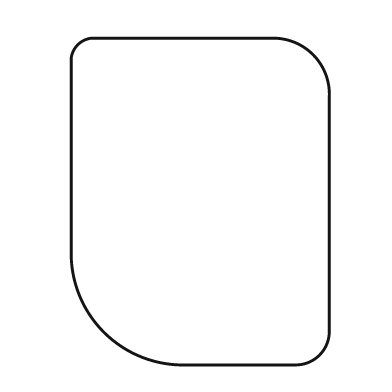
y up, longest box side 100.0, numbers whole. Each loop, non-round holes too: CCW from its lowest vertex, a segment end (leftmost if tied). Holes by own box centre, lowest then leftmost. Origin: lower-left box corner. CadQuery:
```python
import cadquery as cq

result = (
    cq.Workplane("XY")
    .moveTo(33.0, 0.0)
    .lineTo(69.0, 0.0)
    .threePointArc((76.0, 3.0), (79.0, 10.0))
    .lineTo(79.0, 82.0)
    .threePointArc((74.0, 95.0), (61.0, 100.0))
    .lineTo(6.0, 100.0)
    .threePointArc((2.0, 98.0), (0.0, 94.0))
    .lineTo(0.0, 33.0)
    .threePointArc((10.0, 10.0), (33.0, 0.0))
    .close()
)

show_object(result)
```